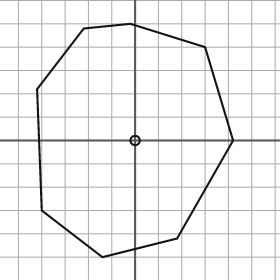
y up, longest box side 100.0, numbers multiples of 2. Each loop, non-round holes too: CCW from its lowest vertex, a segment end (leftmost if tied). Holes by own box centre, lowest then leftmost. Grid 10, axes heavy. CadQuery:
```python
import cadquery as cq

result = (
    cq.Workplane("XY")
    .moveTo(-14.0, -50.0)
    .lineTo(18.0, -42.0)
    .lineTo(42.0, 0.0)
    .lineTo(30.0, 40.0)
    .lineTo(-2.0, 50.0)
    .lineTo(-22.0, 48.0)
    .lineTo(-42.0, 22.0)
    .lineTo(-40.0, -30.0)
    .close()
    .moveTo(0.0, 0.0)
    .circle(2.0)
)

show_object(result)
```